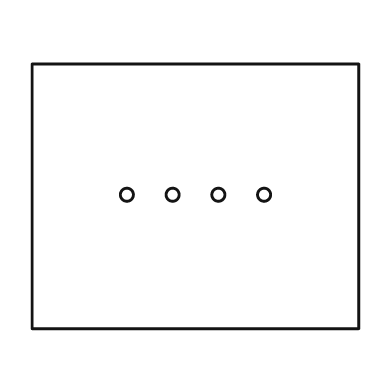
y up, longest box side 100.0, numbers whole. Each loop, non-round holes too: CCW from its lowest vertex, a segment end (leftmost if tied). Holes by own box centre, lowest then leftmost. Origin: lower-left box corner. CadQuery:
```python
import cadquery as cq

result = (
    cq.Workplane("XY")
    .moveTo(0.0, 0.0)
    .lineTo(100.0, 0.0)
    .lineTo(100.0, 81.0)
    .lineTo(0.0, 81.0)
    .close()
    .moveTo(29.0, 41.0)
    .circle(2.0)
    .moveTo(43.0, 41.0)
    .circle(2.0)
    .moveTo(57.0, 41.0)
    .circle(2.0)
    .moveTo(71.0, 41.0)
    .circle(2.0)
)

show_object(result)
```